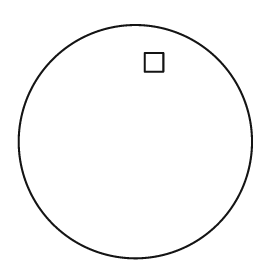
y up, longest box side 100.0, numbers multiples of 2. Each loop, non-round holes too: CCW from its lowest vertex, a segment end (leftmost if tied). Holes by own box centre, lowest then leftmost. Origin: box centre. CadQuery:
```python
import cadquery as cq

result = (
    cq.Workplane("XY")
    .moveTo(0.0, 0.0)
    .circle(50.0)
    .moveTo(4.0, 30.0)
    .lineTo(12.0, 30.0)
    .lineTo(12.0, 38.0)
    .lineTo(4.0, 38.0)
    .close()
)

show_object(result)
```